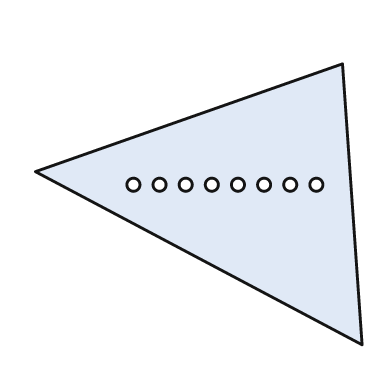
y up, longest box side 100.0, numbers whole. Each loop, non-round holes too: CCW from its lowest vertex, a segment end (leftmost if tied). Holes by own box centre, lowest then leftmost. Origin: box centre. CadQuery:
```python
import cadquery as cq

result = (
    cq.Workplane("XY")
    .moveTo(50.0, -43.0)
    .lineTo(44.0, 43.0)
    .lineTo(-50.0, 10.0)
    .close()
    .moveTo(-20.0, 6.0)
    .circle(2.0)
    .moveTo(-12.0, 6.0)
    .circle(2.0)
    .moveTo(-4.0, 6.0)
    .circle(2.0)
    .moveTo(4.0, 6.0)
    .circle(2.0)
    .moveTo(12.0, 6.0)
    .circle(2.0)
    .moveTo(20.0, 6.0)
    .circle(2.0)
    .moveTo(28.0, 6.0)
    .circle(2.0)
    .moveTo(36.0, 6.0)
    .circle(2.0)
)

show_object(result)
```